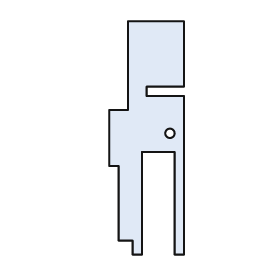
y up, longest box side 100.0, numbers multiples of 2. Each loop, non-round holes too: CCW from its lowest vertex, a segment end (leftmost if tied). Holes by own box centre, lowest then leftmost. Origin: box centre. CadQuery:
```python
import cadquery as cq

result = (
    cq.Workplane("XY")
    .moveTo(-6.0, -50.0)
    .lineTo(-2.0, -50.0)
    .lineTo(-2.0, -6.0)
    .lineTo(12.0, -6.0)
    .lineTo(12.0, -50.0)
    .lineTo(16.0, -50.0)
    .lineTo(16.0, 18.0)
    .lineTo(0.0, 18.0)
    .lineTo(0.0, 22.0)
    .lineTo(16.0, 22.0)
    .lineTo(16.0, 50.0)
    .lineTo(-8.0, 50.0)
    .lineTo(-8.0, 12.0)
    .lineTo(-16.0, 12.0)
    .lineTo(-16.0, -12.0)
    .lineTo(-12.0, -12.0)
    .lineTo(-12.0, -44.0)
    .lineTo(-6.0, -44.0)
    .close()
    .moveTo(10.0, 2.0)
    .circle(2.0)
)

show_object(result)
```